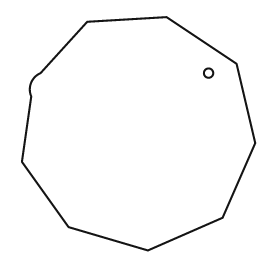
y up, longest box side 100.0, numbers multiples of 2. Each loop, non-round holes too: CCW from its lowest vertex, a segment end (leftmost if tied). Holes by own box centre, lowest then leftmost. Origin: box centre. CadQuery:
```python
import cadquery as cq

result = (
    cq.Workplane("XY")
    .moveTo(4.0, -50.0)
    .lineTo(36.0, -36.0)
    .lineTo(50.0, -4.0)
    .lineTo(42.0, 30.0)
    .lineTo(12.0, 50.0)
    .lineTo(-22.0, 48.0)
    .lineTo(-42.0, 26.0)
    .threePointArc((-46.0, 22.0), (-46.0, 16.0))
    .lineTo(-50.0, -12.0)
    .lineTo(-30.0, -40.0)
    .close()
    .moveTo(30.0, 26.0)
    .circle(2.0)
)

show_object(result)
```